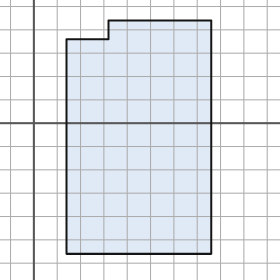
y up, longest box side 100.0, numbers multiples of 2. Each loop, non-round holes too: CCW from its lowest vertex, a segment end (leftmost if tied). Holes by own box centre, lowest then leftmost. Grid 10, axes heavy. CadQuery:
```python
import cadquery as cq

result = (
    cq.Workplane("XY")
    .moveTo(14.0, -56.0)
    .lineTo(76.0, -56.0)
    .lineTo(76.0, 44.0)
    .lineTo(32.0, 44.0)
    .lineTo(32.0, 36.0)
    .lineTo(14.0, 36.0)
    .close()
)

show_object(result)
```